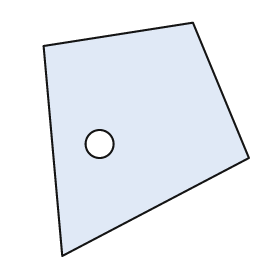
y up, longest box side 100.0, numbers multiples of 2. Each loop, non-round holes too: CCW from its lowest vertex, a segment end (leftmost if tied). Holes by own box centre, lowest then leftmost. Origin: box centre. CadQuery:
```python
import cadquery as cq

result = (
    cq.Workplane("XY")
    .moveTo(-36.0, -50.0)
    .lineTo(44.0, -8.0)
    .lineTo(20.0, 50.0)
    .lineTo(-44.0, 40.0)
    .close()
    .moveTo(-20.0, -2.0)
    .circle(6.0)
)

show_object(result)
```